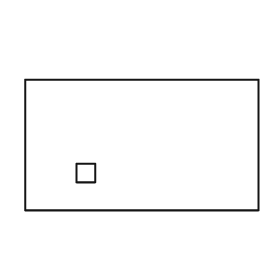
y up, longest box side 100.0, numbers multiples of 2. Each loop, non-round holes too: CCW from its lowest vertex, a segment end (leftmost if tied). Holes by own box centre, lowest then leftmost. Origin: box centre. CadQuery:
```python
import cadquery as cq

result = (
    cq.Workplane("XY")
    .moveTo(-50.0, -28.0)
    .lineTo(50.0, -28.0)
    .lineTo(50.0, 28.0)
    .lineTo(-50.0, 28.0)
    .close()
    .moveTo(-28.0, -16.0)
    .lineTo(-20.0, -16.0)
    .lineTo(-20.0, -8.0)
    .lineTo(-28.0, -8.0)
    .close()
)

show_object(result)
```